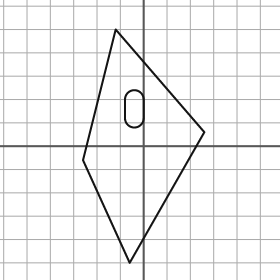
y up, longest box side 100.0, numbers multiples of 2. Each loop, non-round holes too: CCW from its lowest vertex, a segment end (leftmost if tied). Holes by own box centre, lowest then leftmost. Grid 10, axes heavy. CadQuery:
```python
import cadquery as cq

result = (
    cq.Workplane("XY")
    .moveTo(-6.0, -50.0)
    .lineTo(26.0, 6.0)
    .lineTo(-12.0, 50.0)
    .lineTo(-26.0, -6.0)
    .close()
    .moveTo(-8.0, 12.0)
    .threePointArc((-4.0, 8.0), (0.0, 12.0))
    .lineTo(0.0, 20.0)
    .threePointArc((-4.0, 24.0), (-8.0, 20.0))
    .close()
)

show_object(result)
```